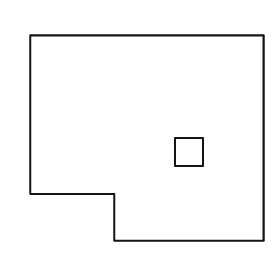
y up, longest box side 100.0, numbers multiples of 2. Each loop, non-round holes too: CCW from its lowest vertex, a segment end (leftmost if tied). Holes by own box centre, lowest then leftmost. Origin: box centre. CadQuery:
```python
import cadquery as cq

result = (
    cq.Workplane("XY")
    .moveTo(-14.0, -44.0)
    .lineTo(50.0, -44.0)
    .lineTo(50.0, 44.0)
    .lineTo(-50.0, 44.0)
    .lineTo(-50.0, -24.0)
    .lineTo(-14.0, -24.0)
    .close()
    .moveTo(12.0, -12.0)
    .lineTo(24.0, -12.0)
    .lineTo(24.0, 0.0)
    .lineTo(12.0, 0.0)
    .close()
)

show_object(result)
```